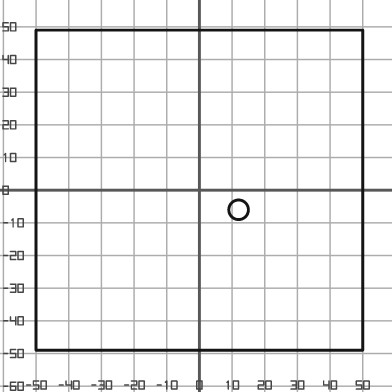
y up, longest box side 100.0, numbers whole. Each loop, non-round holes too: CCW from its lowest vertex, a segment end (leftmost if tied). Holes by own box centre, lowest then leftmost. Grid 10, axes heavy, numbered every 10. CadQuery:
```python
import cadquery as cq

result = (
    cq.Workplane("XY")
    .moveTo(-50.0, -49.0)
    .lineTo(50.0, -49.0)
    .lineTo(50.0, 49.0)
    .lineTo(-50.0, 49.0)
    .close()
    .moveTo(12.0, -6.0)
    .circle(3.0)
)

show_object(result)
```